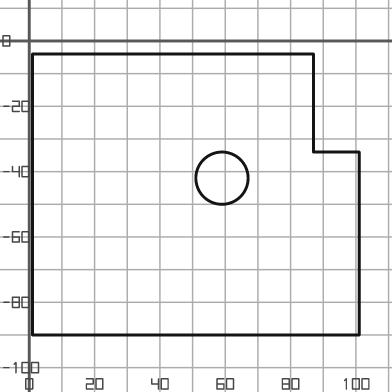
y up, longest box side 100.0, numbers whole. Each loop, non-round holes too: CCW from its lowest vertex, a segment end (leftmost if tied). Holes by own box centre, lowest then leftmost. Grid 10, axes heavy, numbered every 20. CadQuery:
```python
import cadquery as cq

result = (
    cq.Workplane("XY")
    .moveTo(1.0, -90.0)
    .lineTo(101.0, -90.0)
    .lineTo(101.0, -34.0)
    .lineTo(87.0, -34.0)
    .lineTo(87.0, -4.0)
    .lineTo(1.0, -4.0)
    .close()
    .moveTo(59.0, -42.0)
    .circle(8.0)
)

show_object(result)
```